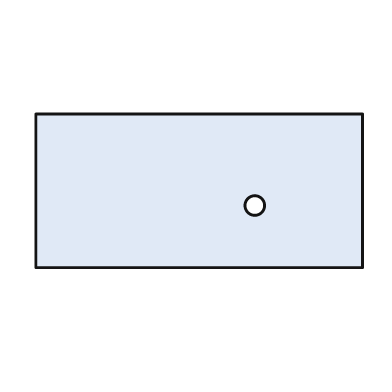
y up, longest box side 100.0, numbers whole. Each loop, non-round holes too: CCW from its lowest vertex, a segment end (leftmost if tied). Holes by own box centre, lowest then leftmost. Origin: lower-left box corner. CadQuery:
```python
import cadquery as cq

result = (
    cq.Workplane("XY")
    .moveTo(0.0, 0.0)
    .lineTo(100.0, 0.0)
    .lineTo(100.0, 47.0)
    .lineTo(0.0, 47.0)
    .close()
    .moveTo(67.0, 19.0)
    .circle(3.0)
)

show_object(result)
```